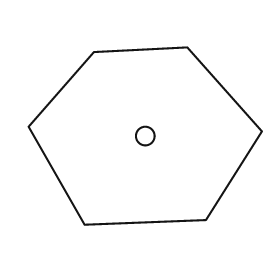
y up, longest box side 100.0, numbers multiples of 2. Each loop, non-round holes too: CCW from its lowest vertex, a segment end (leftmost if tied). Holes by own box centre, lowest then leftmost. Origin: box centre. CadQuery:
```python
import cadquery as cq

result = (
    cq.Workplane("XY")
    .moveTo(-26.0, -38.0)
    .lineTo(26.0, -36.0)
    .lineTo(50.0, 2.0)
    .lineTo(18.0, 38.0)
    .lineTo(-22.0, 36.0)
    .lineTo(-50.0, 4.0)
    .close()
    .moveTo(0.0, 0.0)
    .circle(4.0)
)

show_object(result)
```